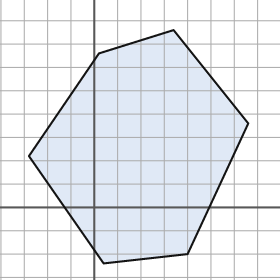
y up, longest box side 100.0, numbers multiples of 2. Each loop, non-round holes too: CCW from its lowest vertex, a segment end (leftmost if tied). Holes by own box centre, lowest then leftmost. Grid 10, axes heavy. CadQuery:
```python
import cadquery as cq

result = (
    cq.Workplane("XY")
    .moveTo(4.0, -24.0)
    .lineTo(40.0, -20.0)
    .lineTo(66.0, 36.0)
    .lineTo(34.0, 76.0)
    .lineTo(2.0, 66.0)
    .lineTo(-28.0, 22.0)
    .close()
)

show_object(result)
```